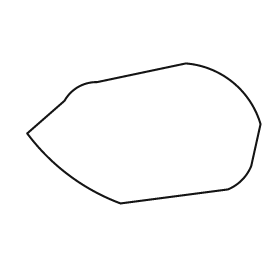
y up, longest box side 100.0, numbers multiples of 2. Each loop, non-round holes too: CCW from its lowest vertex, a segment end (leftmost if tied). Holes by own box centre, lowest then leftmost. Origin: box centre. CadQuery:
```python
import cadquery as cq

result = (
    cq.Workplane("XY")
    .moveTo(-10.0, -30.0)
    .lineTo(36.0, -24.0)
    .threePointArc((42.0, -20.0), (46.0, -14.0))
    .lineTo(50.0, 4.0)
    .threePointArc((38.0, 22.0), (18.0, 30.0))
    .lineTo(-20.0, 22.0)
    .threePointArc((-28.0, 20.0), (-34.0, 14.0))
    .lineTo(-50.0, 0.0)
    .threePointArc((-32.0, -18.0), (-10.0, -30.0))
    .close()
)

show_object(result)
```